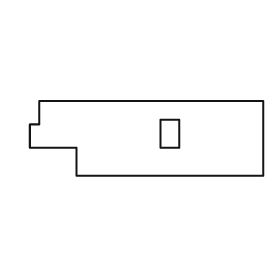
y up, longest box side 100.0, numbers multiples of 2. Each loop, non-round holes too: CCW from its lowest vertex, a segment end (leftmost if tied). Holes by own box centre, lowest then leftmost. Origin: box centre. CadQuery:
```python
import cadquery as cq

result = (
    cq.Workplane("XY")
    .moveTo(-30.0, -16.0)
    .lineTo(50.0, -16.0)
    .lineTo(50.0, 16.0)
    .lineTo(-46.0, 16.0)
    .lineTo(-46.0, 6.0)
    .lineTo(-50.0, 6.0)
    .lineTo(-50.0, -4.0)
    .lineTo(-30.0, -4.0)
    .close()
    .moveTo(6.0, -4.0)
    .lineTo(14.0, -4.0)
    .lineTo(14.0, 8.0)
    .lineTo(6.0, 8.0)
    .close()
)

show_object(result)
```